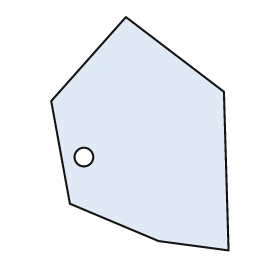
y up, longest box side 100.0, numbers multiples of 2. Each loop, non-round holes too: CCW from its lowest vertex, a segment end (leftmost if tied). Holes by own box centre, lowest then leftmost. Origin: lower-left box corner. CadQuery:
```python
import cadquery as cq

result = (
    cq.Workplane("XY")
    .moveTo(76.0, 0.0)
    .lineTo(74.0, 68.0)
    .lineTo(32.0, 100.0)
    .lineTo(0.0, 64.0)
    .lineTo(8.0, 20.0)
    .lineTo(46.0, 4.0)
    .close()
    .moveTo(14.0, 40.0)
    .circle(4.0)
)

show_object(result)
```